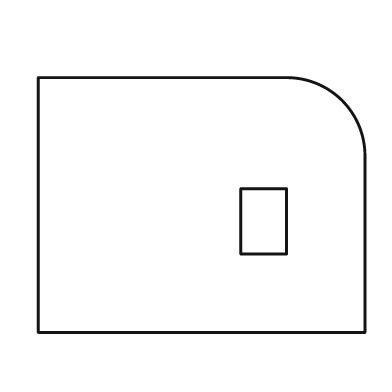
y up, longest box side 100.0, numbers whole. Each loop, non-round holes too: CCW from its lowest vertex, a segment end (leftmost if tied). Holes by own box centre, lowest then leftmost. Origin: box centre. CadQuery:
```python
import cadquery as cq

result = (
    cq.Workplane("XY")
    .moveTo(-50.0, -39.0)
    .lineTo(50.0, -39.0)
    .lineTo(50.0, 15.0)
    .threePointArc((43.0, 32.0), (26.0, 39.0))
    .lineTo(-50.0, 39.0)
    .close()
    .moveTo(12.0, -15.0)
    .lineTo(26.0, -15.0)
    .lineTo(26.0, 5.0)
    .lineTo(12.0, 5.0)
    .close()
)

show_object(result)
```